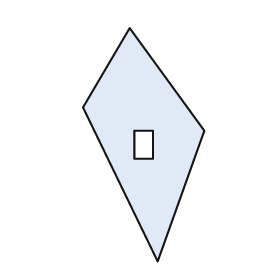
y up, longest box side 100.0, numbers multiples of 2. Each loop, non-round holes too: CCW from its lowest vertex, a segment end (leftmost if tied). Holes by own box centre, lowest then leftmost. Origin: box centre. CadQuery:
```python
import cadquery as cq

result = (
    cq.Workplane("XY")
    .moveTo(6.0, -50.0)
    .lineTo(26.0, 6.0)
    .lineTo(-6.0, 50.0)
    .lineTo(-26.0, 16.0)
    .close()
    .moveTo(-4.0, -6.0)
    .lineTo(4.0, -6.0)
    .lineTo(4.0, 6.0)
    .lineTo(-4.0, 6.0)
    .close()
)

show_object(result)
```